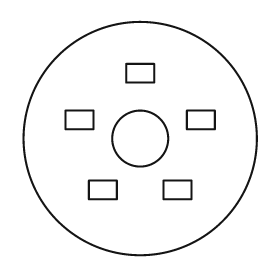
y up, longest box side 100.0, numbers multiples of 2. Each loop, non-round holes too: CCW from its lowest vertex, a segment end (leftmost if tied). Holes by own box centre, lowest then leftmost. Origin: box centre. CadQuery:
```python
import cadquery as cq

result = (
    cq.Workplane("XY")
    .moveTo(0.0, 0.0)
    .circle(50.0)
    .moveTo(-22.0, -26.0)
    .lineTo(-10.0, -26.0)
    .lineTo(-10.0, -18.0)
    .lineTo(-22.0, -18.0)
    .close()
    .moveTo(10.0, -26.0)
    .lineTo(22.0, -26.0)
    .lineTo(22.0, -18.0)
    .lineTo(10.0, -18.0)
    .close()
    .moveTo(0.0, 0.0)
    .circle(12.0)
    .moveTo(-32.0, 4.0)
    .lineTo(-20.0, 4.0)
    .lineTo(-20.0, 12.0)
    .lineTo(-32.0, 12.0)
    .close()
    .moveTo(20.0, 4.0)
    .lineTo(32.0, 4.0)
    .lineTo(32.0, 12.0)
    .lineTo(20.0, 12.0)
    .close()
    .moveTo(-6.0, 24.0)
    .lineTo(6.0, 24.0)
    .lineTo(6.0, 32.0)
    .lineTo(-6.0, 32.0)
    .close()
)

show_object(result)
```